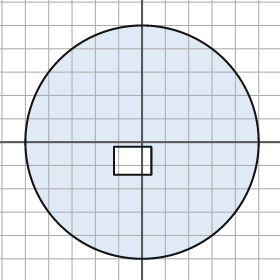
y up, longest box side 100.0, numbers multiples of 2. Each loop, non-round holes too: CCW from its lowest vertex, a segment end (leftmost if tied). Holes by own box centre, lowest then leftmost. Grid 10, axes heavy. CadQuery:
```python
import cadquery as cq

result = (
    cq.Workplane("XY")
    .moveTo(0.0, 0.0)
    .circle(50.0)
    .moveTo(-12.0, -14.0)
    .lineTo(4.0, -14.0)
    .lineTo(4.0, -2.0)
    .lineTo(-12.0, -2.0)
    .close()
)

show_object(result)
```